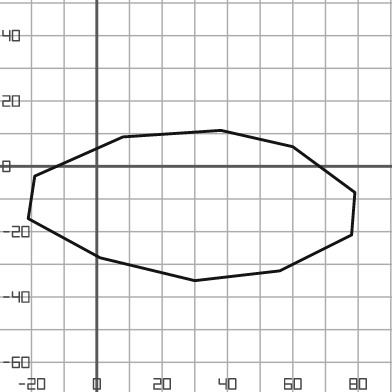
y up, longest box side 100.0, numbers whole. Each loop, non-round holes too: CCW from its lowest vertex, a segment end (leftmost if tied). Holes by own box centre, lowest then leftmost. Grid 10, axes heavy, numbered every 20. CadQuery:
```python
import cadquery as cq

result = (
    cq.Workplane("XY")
    .moveTo(30.0, -35.0)
    .lineTo(56.0, -32.0)
    .lineTo(78.0, -21.0)
    .lineTo(79.0, -8.0)
    .lineTo(60.0, 6.0)
    .lineTo(38.0, 11.0)
    .lineTo(8.0, 9.0)
    .lineTo(-19.0, -3.0)
    .lineTo(-21.0, -16.0)
    .lineTo(1.0, -28.0)
    .close()
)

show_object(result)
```